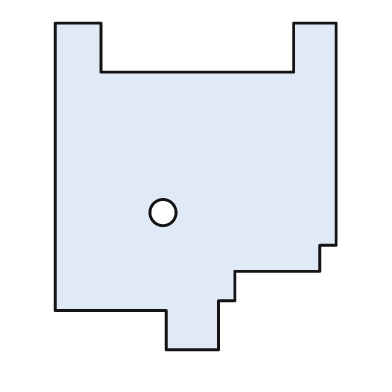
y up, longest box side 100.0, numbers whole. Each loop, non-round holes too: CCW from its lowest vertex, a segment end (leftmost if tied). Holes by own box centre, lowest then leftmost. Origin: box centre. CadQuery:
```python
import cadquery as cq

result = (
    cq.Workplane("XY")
    .moveTo(-9.0, -50.0)
    .lineTo(7.0, -50.0)
    .lineTo(7.0, -35.0)
    .lineTo(12.0, -35.0)
    .lineTo(12.0, -26.0)
    .lineTo(38.0, -26.0)
    .lineTo(38.0, -18.0)
    .lineTo(43.0, -18.0)
    .lineTo(43.0, 50.0)
    .lineTo(30.0, 50.0)
    .lineTo(30.0, 35.0)
    .lineTo(-29.0, 35.0)
    .lineTo(-29.0, 50.0)
    .lineTo(-43.0, 50.0)
    .lineTo(-43.0, -38.0)
    .lineTo(-9.0, -38.0)
    .close()
    .moveTo(-10.0, -8.0)
    .circle(4.0)
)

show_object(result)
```